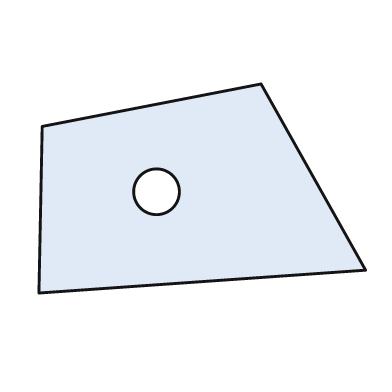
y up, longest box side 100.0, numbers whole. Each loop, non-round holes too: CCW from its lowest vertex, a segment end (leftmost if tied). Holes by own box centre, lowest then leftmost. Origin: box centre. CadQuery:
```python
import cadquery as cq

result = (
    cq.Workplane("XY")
    .moveTo(-50.0, -32.0)
    .lineTo(50.0, -25.0)
    .lineTo(18.0, 32.0)
    .lineTo(-49.0, 19.0)
    .close()
    .moveTo(-14.0, -1.0)
    .circle(7.0)
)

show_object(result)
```